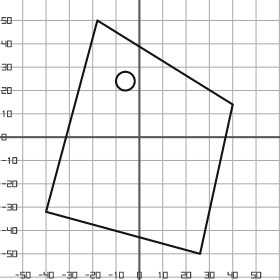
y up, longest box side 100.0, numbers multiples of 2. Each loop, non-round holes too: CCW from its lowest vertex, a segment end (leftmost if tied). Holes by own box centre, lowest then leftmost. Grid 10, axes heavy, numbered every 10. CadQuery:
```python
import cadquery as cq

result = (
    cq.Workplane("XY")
    .moveTo(26.0, -50.0)
    .lineTo(40.0, 14.0)
    .lineTo(-18.0, 50.0)
    .lineTo(-40.0, -32.0)
    .close()
    .moveTo(-6.0, 24.0)
    .circle(4.0)
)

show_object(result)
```